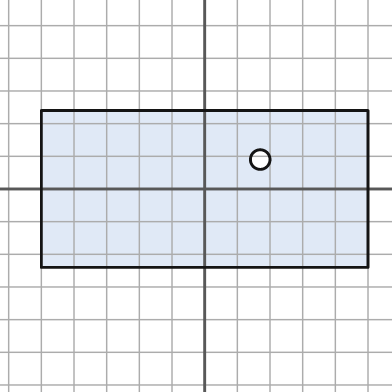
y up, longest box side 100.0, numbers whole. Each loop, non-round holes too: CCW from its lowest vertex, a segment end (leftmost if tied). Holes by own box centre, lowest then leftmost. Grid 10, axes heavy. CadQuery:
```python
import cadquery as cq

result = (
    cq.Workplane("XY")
    .moveTo(-50.0, -24.0)
    .lineTo(50.0, -24.0)
    .lineTo(50.0, 24.0)
    .lineTo(-50.0, 24.0)
    .close()
    .moveTo(17.0, 9.0)
    .circle(3.0)
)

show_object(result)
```